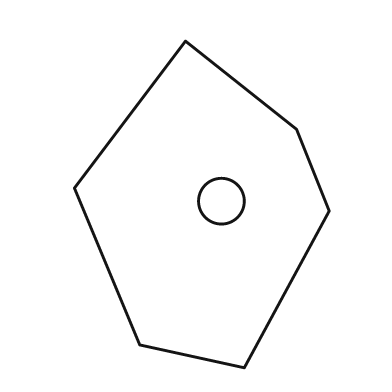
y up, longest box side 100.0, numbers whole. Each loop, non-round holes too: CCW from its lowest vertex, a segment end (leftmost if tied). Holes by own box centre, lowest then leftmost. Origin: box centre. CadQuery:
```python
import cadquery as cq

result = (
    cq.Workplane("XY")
    .moveTo(13.0, -50.0)
    .lineTo(39.0, -2.0)
    .lineTo(29.0, 23.0)
    .lineTo(-5.0, 50.0)
    .lineTo(-39.0, 5.0)
    .lineTo(-19.0, -43.0)
    .close()
    .moveTo(6.0, 1.0)
    .circle(7.0)
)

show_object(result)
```